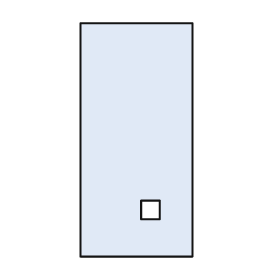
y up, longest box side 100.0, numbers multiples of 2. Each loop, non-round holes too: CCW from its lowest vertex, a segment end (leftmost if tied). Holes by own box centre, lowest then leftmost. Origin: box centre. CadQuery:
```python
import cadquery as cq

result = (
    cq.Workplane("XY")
    .moveTo(-24.0, -50.0)
    .lineTo(24.0, -50.0)
    .lineTo(24.0, 50.0)
    .lineTo(-24.0, 50.0)
    .close()
    .moveTo(2.0, -34.0)
    .lineTo(10.0, -34.0)
    .lineTo(10.0, -26.0)
    .lineTo(2.0, -26.0)
    .close()
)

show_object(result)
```